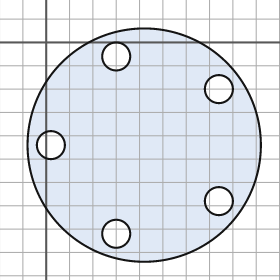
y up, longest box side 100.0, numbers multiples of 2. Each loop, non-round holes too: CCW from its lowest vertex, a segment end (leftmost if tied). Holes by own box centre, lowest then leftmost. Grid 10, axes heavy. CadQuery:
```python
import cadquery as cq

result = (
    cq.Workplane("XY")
    .moveTo(42.0, -44.0)
    .circle(50.0)
    .moveTo(30.0, -82.0)
    .circle(6.0)
    .moveTo(74.0, -68.0)
    .circle(6.0)
    .moveTo(2.0, -44.0)
    .circle(6.0)
    .moveTo(74.0, -20.0)
    .circle(6.0)
    .moveTo(30.0, -6.0)
    .circle(6.0)
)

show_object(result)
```